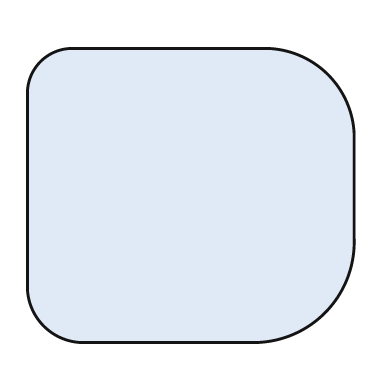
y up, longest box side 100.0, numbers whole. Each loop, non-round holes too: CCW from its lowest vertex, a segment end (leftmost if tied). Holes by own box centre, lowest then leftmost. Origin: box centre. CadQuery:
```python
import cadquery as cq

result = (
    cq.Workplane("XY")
    .moveTo(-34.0, -45.0)
    .lineTo(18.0, -45.0)
    .threePointArc((41.0, -36.0), (50.0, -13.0))
    .lineTo(50.0, 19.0)
    .threePointArc((42.0, 37.0), (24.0, 45.0))
    .lineTo(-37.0, 45.0)
    .threePointArc((-46.0, 41.0), (-50.0, 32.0))
    .lineTo(-50.0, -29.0)
    .threePointArc((-45.0, -40.0), (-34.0, -45.0))
    .close()
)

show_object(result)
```